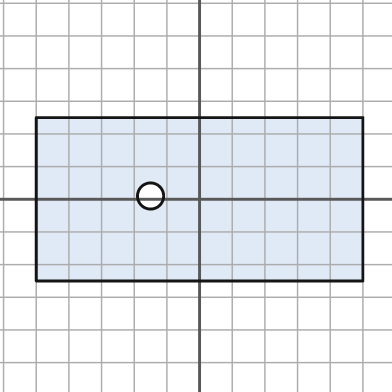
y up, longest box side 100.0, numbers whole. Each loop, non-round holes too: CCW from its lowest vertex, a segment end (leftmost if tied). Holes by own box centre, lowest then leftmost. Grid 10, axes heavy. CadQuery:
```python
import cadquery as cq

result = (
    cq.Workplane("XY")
    .moveTo(-50.0, -25.0)
    .lineTo(50.0, -25.0)
    .lineTo(50.0, 25.0)
    .lineTo(-50.0, 25.0)
    .close()
    .moveTo(-15.0, 1.0)
    .circle(4.0)
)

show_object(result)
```